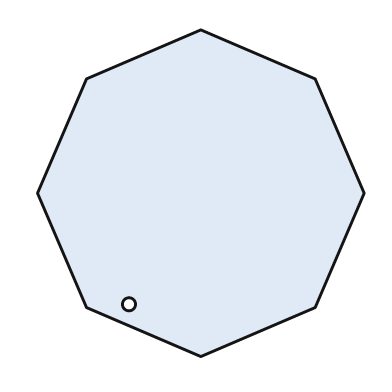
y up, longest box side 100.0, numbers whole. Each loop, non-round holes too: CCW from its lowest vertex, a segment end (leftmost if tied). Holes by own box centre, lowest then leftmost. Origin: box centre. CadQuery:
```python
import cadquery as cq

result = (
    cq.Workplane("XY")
    .moveTo(0.0, -50.0)
    .lineTo(35.0, -35.0)
    .lineTo(50.0, 0.0)
    .lineTo(35.0, 35.0)
    .lineTo(0.0, 50.0)
    .lineTo(-35.0, 35.0)
    .lineTo(-50.0, 0.0)
    .lineTo(-35.0, -35.0)
    .close()
    .moveTo(-22.0, -34.0)
    .circle(2.0)
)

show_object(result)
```